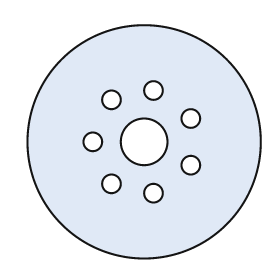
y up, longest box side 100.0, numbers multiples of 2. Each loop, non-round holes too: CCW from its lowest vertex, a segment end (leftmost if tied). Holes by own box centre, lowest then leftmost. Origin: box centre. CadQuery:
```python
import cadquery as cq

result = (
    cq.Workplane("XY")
    .moveTo(0.0, 0.0)
    .circle(50.0)
    .moveTo(4.0, -22.0)
    .circle(4.0)
    .moveTo(-14.0, -18.0)
    .circle(4.0)
    .moveTo(20.0, -10.0)
    .circle(4.0)
    .moveTo(-22.0, 0.0)
    .circle(4.0)
    .moveTo(0.0, 0.0)
    .circle(10.0)
    .moveTo(20.0, 10.0)
    .circle(4.0)
    .moveTo(-14.0, 18.0)
    .circle(4.0)
    .moveTo(4.0, 22.0)
    .circle(4.0)
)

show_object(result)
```